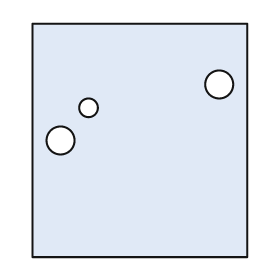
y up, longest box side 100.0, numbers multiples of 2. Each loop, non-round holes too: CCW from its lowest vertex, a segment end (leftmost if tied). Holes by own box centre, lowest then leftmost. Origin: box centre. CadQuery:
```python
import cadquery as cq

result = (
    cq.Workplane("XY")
    .moveTo(-46.0, -50.0)
    .lineTo(46.0, -50.0)
    .lineTo(46.0, 50.0)
    .lineTo(-46.0, 50.0)
    .close()
    .moveTo(-34.0, 0.0)
    .circle(6.0)
    .moveTo(-22.0, 14.0)
    .circle(4.0)
    .moveTo(34.0, 24.0)
    .circle(6.0)
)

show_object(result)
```